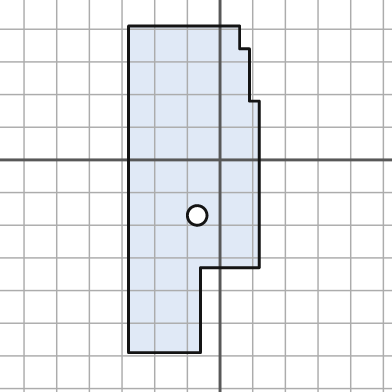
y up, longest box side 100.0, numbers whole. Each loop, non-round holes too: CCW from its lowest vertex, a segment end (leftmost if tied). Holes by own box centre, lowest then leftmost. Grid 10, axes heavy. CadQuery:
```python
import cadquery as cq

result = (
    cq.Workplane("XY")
    .moveTo(-28.0, -59.0)
    .lineTo(-6.0, -59.0)
    .lineTo(-6.0, -33.0)
    .lineTo(12.0, -33.0)
    .lineTo(12.0, 18.0)
    .lineTo(9.0, 18.0)
    .lineTo(9.0, 34.0)
    .lineTo(6.0, 34.0)
    .lineTo(6.0, 41.0)
    .lineTo(-28.0, 41.0)
    .close()
    .moveTo(-7.0, -17.0)
    .circle(3.0)
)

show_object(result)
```